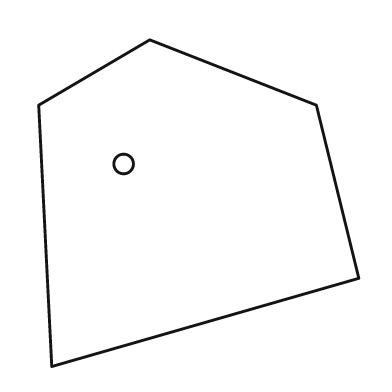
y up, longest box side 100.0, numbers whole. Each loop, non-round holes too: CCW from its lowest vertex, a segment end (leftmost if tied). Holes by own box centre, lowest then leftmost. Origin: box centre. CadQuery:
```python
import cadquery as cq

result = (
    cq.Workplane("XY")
    .moveTo(-45.0, -50.0)
    .lineTo(49.0, -23.0)
    .lineTo(36.0, 30.0)
    .lineTo(-15.0, 50.0)
    .lineTo(-49.0, 30.0)
    .close()
    .moveTo(-23.0, 12.0)
    .circle(3.0)
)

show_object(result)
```